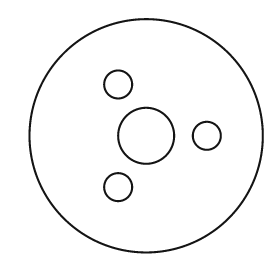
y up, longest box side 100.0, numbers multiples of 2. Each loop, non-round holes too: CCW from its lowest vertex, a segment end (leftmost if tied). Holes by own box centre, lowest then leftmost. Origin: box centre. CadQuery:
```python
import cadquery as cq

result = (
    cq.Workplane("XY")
    .moveTo(0.0, 0.0)
    .circle(50.0)
    .moveTo(-12.0, -22.0)
    .circle(6.0)
    .moveTo(0.0, 0.0)
    .circle(12.0)
    .moveTo(26.0, 0.0)
    .circle(6.0)
    .moveTo(-12.0, 22.0)
    .circle(6.0)
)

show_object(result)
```